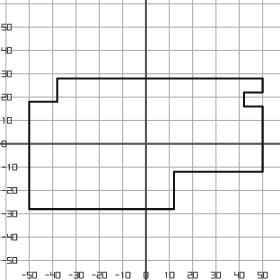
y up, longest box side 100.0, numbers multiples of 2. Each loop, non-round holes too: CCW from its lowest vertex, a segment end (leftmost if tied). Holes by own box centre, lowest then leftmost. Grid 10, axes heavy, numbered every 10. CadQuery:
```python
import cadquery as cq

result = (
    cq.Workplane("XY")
    .moveTo(-50.0, -28.0)
    .lineTo(12.0, -28.0)
    .lineTo(12.0, -12.0)
    .lineTo(50.0, -12.0)
    .lineTo(50.0, 16.0)
    .lineTo(42.0, 16.0)
    .lineTo(42.0, 22.0)
    .lineTo(50.0, 22.0)
    .lineTo(50.0, 28.0)
    .lineTo(-38.0, 28.0)
    .lineTo(-38.0, 18.0)
    .lineTo(-50.0, 18.0)
    .close()
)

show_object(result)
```